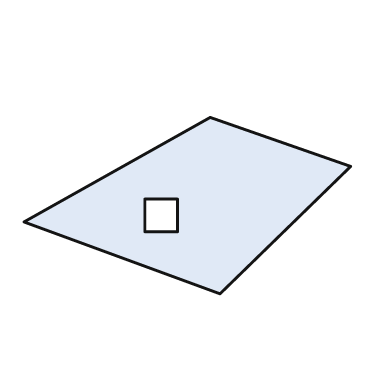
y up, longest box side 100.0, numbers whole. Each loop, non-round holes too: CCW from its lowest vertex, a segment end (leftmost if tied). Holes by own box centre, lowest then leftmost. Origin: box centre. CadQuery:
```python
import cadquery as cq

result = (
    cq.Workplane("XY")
    .moveTo(10.0, -27.0)
    .lineTo(50.0, 12.0)
    .lineTo(7.0, 27.0)
    .lineTo(-50.0, -5.0)
    .close()
    .moveTo(-13.0, -8.0)
    .lineTo(-3.0, -8.0)
    .lineTo(-3.0, 2.0)
    .lineTo(-13.0, 2.0)
    .close()
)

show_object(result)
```